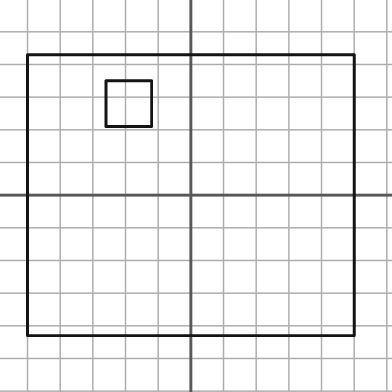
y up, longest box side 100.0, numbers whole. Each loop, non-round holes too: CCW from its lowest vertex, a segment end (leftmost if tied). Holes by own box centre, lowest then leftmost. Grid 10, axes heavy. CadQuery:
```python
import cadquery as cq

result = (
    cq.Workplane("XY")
    .moveTo(-50.0, -43.0)
    .lineTo(50.0, -43.0)
    .lineTo(50.0, 43.0)
    .lineTo(-50.0, 43.0)
    .close()
    .moveTo(-26.0, 21.0)
    .lineTo(-12.0, 21.0)
    .lineTo(-12.0, 35.0)
    .lineTo(-26.0, 35.0)
    .close()
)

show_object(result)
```